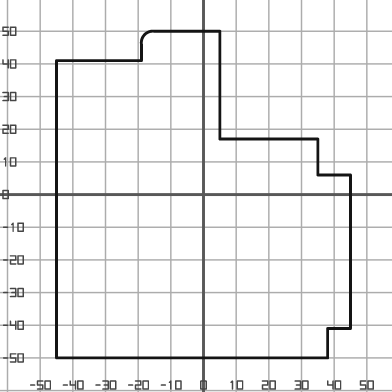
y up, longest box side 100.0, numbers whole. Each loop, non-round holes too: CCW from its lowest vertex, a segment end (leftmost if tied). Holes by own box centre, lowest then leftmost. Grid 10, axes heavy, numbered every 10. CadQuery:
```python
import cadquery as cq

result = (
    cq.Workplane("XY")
    .moveTo(-45.0, -50.0)
    .lineTo(38.0, -50.0)
    .lineTo(38.0, -41.0)
    .lineTo(45.0, -41.0)
    .lineTo(45.0, 6.0)
    .lineTo(35.0, 6.0)
    .lineTo(35.0, 17.0)
    .lineTo(5.0, 17.0)
    .lineTo(5.0, 50.0)
    .lineTo(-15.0, 50.0)
    .threePointArc((-18.0, 49.0), (-19.0, 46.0))
    .lineTo(-19.0, 41.0)
    .lineTo(-45.0, 41.0)
    .close()
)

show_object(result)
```